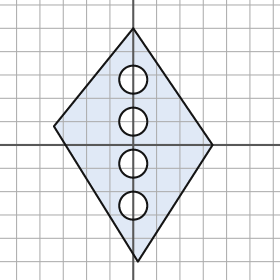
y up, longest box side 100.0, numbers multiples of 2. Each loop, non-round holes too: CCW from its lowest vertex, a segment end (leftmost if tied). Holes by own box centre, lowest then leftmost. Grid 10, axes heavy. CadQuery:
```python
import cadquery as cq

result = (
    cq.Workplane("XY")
    .moveTo(2.0, -50.0)
    .lineTo(34.0, 0.0)
    .lineTo(0.0, 50.0)
    .lineTo(-34.0, 8.0)
    .close()
    .moveTo(0.0, -26.0)
    .circle(6.0)
    .moveTo(0.0, -8.0)
    .circle(6.0)
    .moveTo(0.0, 10.0)
    .circle(6.0)
    .moveTo(0.0, 28.0)
    .circle(6.0)
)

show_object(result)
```